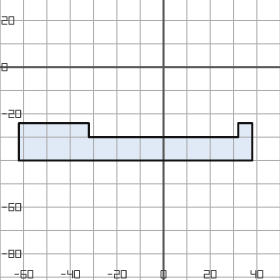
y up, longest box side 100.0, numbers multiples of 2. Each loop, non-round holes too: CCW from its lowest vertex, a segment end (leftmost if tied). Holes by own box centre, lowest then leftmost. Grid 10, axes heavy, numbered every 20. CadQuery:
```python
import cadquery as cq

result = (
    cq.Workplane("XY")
    .moveTo(-62.0, -40.0)
    .lineTo(38.0, -40.0)
    .lineTo(38.0, -24.0)
    .lineTo(32.0, -24.0)
    .lineTo(32.0, -30.0)
    .lineTo(-32.0, -30.0)
    .lineTo(-32.0, -24.0)
    .lineTo(-62.0, -24.0)
    .close()
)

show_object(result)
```